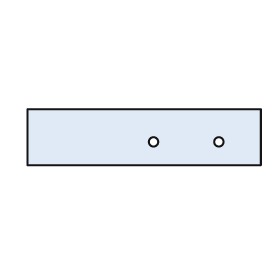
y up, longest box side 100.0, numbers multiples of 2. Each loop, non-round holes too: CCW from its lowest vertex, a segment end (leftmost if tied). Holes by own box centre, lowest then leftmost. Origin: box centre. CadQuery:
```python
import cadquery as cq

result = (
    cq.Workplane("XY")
    .moveTo(-50.0, -12.0)
    .lineTo(50.0, -12.0)
    .lineTo(50.0, 12.0)
    .lineTo(-50.0, 12.0)
    .close()
    .moveTo(4.0, -2.0)
    .circle(2.0)
    .moveTo(32.0, -2.0)
    .circle(2.0)
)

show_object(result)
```